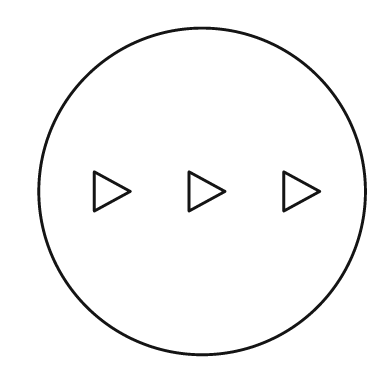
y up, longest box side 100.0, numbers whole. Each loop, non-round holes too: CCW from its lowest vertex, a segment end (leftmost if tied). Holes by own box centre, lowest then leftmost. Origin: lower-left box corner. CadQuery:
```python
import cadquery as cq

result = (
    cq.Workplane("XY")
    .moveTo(50.0, 50.0)
    .circle(50.0)
    .moveTo(17.0, 44.0)
    .lineTo(28.0, 50.0)
    .lineTo(17.0, 56.0)
    .close()
    .moveTo(46.0, 44.0)
    .lineTo(57.0, 50.0)
    .lineTo(46.0, 56.0)
    .close()
    .moveTo(75.0, 44.0)
    .lineTo(86.0, 50.0)
    .lineTo(75.0, 56.0)
    .close()
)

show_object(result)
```